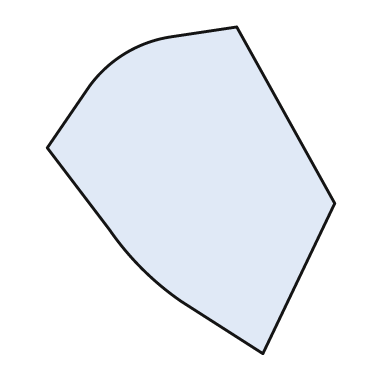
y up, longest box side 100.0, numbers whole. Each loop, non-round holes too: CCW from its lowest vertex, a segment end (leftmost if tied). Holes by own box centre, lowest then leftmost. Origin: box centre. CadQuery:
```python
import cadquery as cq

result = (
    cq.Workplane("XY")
    .moveTo(22.0, -50.0)
    .lineTo(44.0, -4.0)
    .lineTo(14.0, 50.0)
    .lineTo(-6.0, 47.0)
    .threePointArc((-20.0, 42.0), (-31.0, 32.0))
    .lineTo(-44.0, 13.0)
    .lineTo(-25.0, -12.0)
    .threePointArc((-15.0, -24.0), (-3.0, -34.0))
    .close()
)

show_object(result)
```